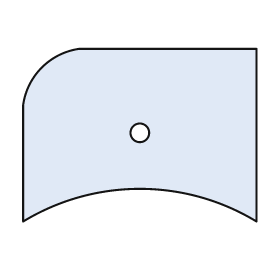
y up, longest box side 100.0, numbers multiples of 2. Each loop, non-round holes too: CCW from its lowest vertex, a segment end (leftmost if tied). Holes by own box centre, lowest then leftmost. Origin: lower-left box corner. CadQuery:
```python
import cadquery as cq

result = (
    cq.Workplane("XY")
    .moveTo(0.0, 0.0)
    .threePointArc((50.0, 14.0), (100.0, 0.0))
    .lineTo(100.0, 74.0)
    .lineTo(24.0, 74.0)
    .threePointArc((8.0, 66.0), (0.0, 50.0))
    .close()
    .moveTo(50.0, 38.0)
    .circle(4.0)
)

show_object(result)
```